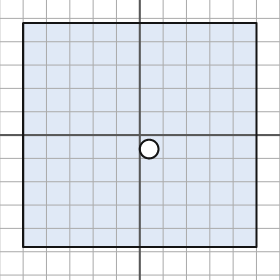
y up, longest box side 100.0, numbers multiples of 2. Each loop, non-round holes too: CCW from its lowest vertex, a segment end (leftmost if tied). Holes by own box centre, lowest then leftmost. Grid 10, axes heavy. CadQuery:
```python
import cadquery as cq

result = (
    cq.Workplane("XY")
    .moveTo(-50.0, -48.0)
    .lineTo(50.0, -48.0)
    .lineTo(50.0, 48.0)
    .lineTo(-50.0, 48.0)
    .close()
    .moveTo(4.0, -6.0)
    .circle(4.0)
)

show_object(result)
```